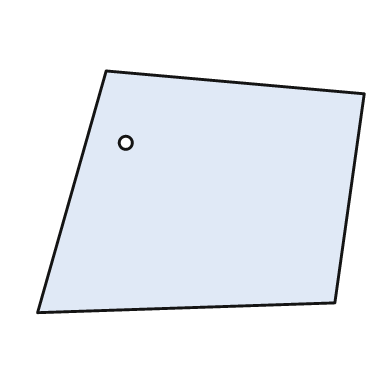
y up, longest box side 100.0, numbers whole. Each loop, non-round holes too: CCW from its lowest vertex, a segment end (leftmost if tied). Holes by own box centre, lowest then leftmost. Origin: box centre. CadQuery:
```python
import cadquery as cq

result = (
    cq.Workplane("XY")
    .moveTo(-50.0, -37.0)
    .lineTo(41.0, -34.0)
    .lineTo(50.0, 30.0)
    .lineTo(-29.0, 37.0)
    .close()
    .moveTo(-23.0, 15.0)
    .circle(2.0)
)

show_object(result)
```